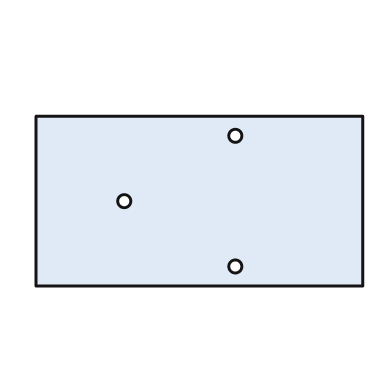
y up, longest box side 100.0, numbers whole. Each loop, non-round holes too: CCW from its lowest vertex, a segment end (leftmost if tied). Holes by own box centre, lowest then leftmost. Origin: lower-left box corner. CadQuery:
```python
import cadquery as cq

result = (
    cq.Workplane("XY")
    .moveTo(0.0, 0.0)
    .lineTo(100.0, 0.0)
    .lineTo(100.0, 52.0)
    .lineTo(0.0, 52.0)
    .close()
    .moveTo(61.0, 6.0)
    .circle(2.0)
    .moveTo(27.0, 26.0)
    .circle(2.0)
    .moveTo(61.0, 46.0)
    .circle(2.0)
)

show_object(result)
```